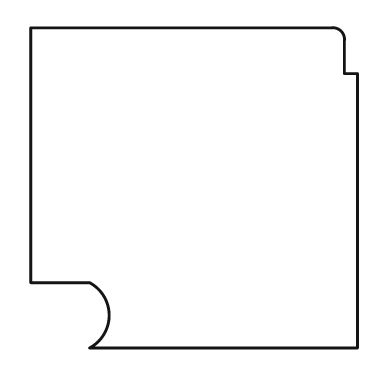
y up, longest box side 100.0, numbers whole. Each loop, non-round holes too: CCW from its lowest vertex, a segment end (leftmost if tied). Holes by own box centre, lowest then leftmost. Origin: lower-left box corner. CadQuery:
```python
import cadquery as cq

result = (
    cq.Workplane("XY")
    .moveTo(18.0, 0.0)
    .lineTo(100.0, 0.0)
    .lineTo(100.0, 84.0)
    .lineTo(96.0, 84.0)
    .lineTo(96.0, 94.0)
    .threePointArc((95.0, 97.0), (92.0, 98.0))
    .lineTo(0.0, 98.0)
    .lineTo(0.0, 20.0)
    .lineTo(18.0, 20.0)
    .threePointArc((24.0, 10.0), (18.0, 0.0))
    .close()
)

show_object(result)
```